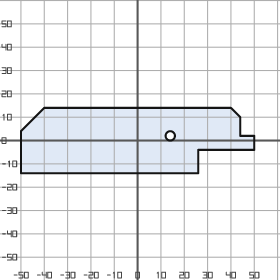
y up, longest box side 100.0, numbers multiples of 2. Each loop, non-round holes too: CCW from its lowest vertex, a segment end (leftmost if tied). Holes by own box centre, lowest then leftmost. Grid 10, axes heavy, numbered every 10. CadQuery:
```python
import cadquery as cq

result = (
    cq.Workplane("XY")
    .moveTo(-50.0, -14.0)
    .lineTo(26.0, -14.0)
    .lineTo(26.0, -4.0)
    .lineTo(50.0, -4.0)
    .lineTo(50.0, 2.0)
    .lineTo(44.0, 2.0)
    .lineTo(44.0, 10.0)
    .lineTo(40.0, 14.0)
    .lineTo(-40.0, 14.0)
    .lineTo(-50.0, 4.0)
    .close()
    .moveTo(14.0, 2.0)
    .circle(2.0)
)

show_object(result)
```